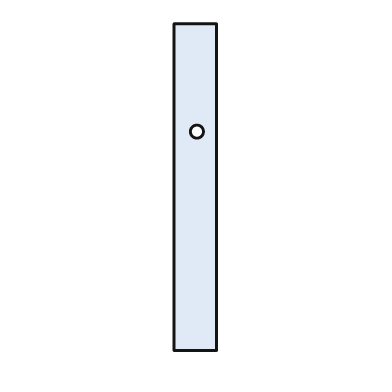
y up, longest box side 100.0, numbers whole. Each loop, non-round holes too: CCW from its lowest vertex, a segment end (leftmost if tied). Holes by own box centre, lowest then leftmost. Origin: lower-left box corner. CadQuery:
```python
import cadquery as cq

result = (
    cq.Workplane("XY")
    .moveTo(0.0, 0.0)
    .lineTo(13.0, 0.0)
    .lineTo(13.0, 100.0)
    .lineTo(0.0, 100.0)
    .close()
    .moveTo(7.0, 67.0)
    .circle(2.0)
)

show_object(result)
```